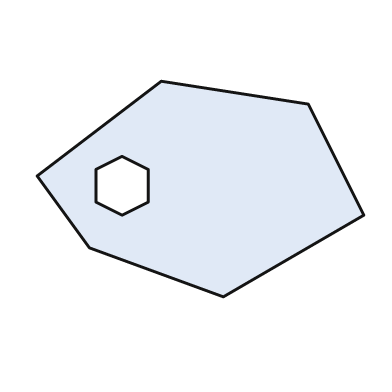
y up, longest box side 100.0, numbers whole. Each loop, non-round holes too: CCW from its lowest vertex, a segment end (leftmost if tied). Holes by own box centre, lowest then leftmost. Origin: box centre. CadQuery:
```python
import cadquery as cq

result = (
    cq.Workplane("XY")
    .moveTo(7.0, -33.0)
    .lineTo(50.0, -8.0)
    .lineTo(33.0, 26.0)
    .lineTo(-12.0, 33.0)
    .lineTo(-50.0, 4.0)
    .lineTo(-34.0, -18.0)
    .close()
    .moveTo(-24.0, -8.0)
    .lineTo(-16.0, -4.0)
    .lineTo(-16.0, 6.0)
    .lineTo(-24.0, 10.0)
    .lineTo(-32.0, 6.0)
    .lineTo(-32.0, -4.0)
    .close()
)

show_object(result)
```